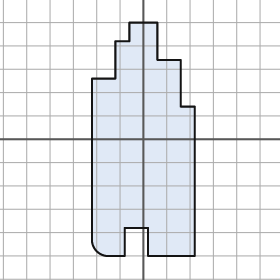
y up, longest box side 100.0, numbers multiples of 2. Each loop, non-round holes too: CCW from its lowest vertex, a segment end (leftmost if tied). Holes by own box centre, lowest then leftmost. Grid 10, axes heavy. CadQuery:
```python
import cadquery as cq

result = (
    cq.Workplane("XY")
    .moveTo(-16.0, -50.0)
    .lineTo(-8.0, -50.0)
    .lineTo(-8.0, -38.0)
    .lineTo(2.0, -38.0)
    .lineTo(2.0, -50.0)
    .lineTo(22.0, -50.0)
    .lineTo(22.0, 14.0)
    .lineTo(16.0, 14.0)
    .lineTo(16.0, 34.0)
    .lineTo(6.0, 34.0)
    .lineTo(6.0, 50.0)
    .lineTo(-6.0, 50.0)
    .lineTo(-6.0, 42.0)
    .lineTo(-12.0, 42.0)
    .lineTo(-12.0, 26.0)
    .lineTo(-22.0, 26.0)
    .lineTo(-22.0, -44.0)
    .threePointArc((-20.0, -48.0), (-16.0, -50.0))
    .close()
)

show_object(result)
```